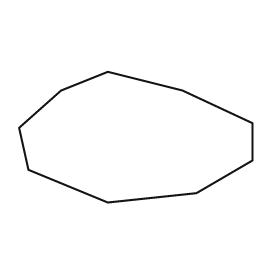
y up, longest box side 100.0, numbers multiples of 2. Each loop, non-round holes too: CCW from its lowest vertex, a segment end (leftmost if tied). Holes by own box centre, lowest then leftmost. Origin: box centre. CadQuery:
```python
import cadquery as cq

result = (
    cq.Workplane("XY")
    .moveTo(-12.0, -28.0)
    .lineTo(26.0, -24.0)
    .lineTo(50.0, -10.0)
    .lineTo(50.0, 6.0)
    .lineTo(20.0, 20.0)
    .lineTo(-12.0, 28.0)
    .lineTo(-32.0, 20.0)
    .lineTo(-50.0, 4.0)
    .lineTo(-46.0, -14.0)
    .close()
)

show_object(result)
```